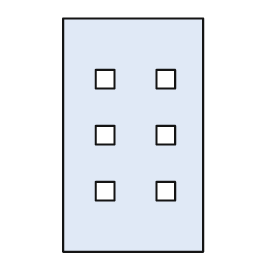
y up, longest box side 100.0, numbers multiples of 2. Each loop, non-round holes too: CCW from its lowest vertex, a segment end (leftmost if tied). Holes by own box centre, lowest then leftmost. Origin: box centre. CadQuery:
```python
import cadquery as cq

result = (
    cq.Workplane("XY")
    .moveTo(-30.0, -50.0)
    .lineTo(30.0, -50.0)
    .lineTo(30.0, 50.0)
    .lineTo(-30.0, 50.0)
    .close()
    .moveTo(-16.0, -28.0)
    .lineTo(-8.0, -28.0)
    .lineTo(-8.0, -20.0)
    .lineTo(-16.0, -20.0)
    .close()
    .moveTo(10.0, -28.0)
    .lineTo(18.0, -28.0)
    .lineTo(18.0, -20.0)
    .lineTo(10.0, -20.0)
    .close()
    .moveTo(-16.0, -4.0)
    .lineTo(-8.0, -4.0)
    .lineTo(-8.0, 4.0)
    .lineTo(-16.0, 4.0)
    .close()
    .moveTo(10.0, -4.0)
    .lineTo(18.0, -4.0)
    .lineTo(18.0, 4.0)
    .lineTo(10.0, 4.0)
    .close()
    .moveTo(-16.0, 20.0)
    .lineTo(-8.0, 20.0)
    .lineTo(-8.0, 28.0)
    .lineTo(-16.0, 28.0)
    .close()
    .moveTo(10.0, 20.0)
    .lineTo(18.0, 20.0)
    .lineTo(18.0, 28.0)
    .lineTo(10.0, 28.0)
    .close()
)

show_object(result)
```